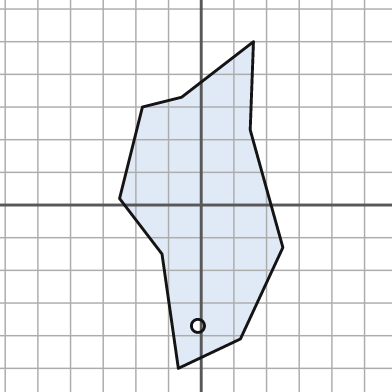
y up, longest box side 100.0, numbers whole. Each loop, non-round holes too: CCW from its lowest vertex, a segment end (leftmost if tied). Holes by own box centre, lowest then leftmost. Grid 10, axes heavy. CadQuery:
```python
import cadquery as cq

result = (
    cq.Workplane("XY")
    .moveTo(-7.0, -50.0)
    .lineTo(12.0, -41.0)
    .lineTo(25.0, -13.0)
    .lineTo(15.0, 23.0)
    .lineTo(16.0, 50.0)
    .lineTo(-6.0, 33.0)
    .lineTo(-18.0, 30.0)
    .lineTo(-25.0, 2.0)
    .lineTo(-12.0, -15.0)
    .close()
    .moveTo(-1.0, -37.0)
    .circle(2.0)
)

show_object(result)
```